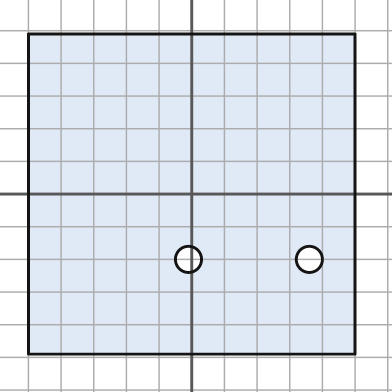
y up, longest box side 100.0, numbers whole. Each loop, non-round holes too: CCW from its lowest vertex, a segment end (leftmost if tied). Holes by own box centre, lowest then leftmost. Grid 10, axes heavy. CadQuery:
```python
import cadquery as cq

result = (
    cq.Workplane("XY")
    .moveTo(-50.0, -49.0)
    .lineTo(50.0, -49.0)
    .lineTo(50.0, 49.0)
    .lineTo(-50.0, 49.0)
    .close()
    .moveTo(-1.0, -20.0)
    .circle(4.0)
    .moveTo(36.0, -20.0)
    .circle(4.0)
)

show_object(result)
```